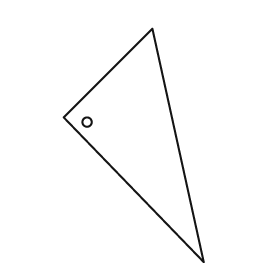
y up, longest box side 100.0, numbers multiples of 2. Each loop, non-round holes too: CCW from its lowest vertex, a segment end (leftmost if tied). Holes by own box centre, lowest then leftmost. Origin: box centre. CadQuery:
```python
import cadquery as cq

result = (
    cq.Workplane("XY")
    .moveTo(30.0, -50.0)
    .lineTo(8.0, 50.0)
    .lineTo(-30.0, 12.0)
    .close()
    .moveTo(-20.0, 10.0)
    .circle(2.0)
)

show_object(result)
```